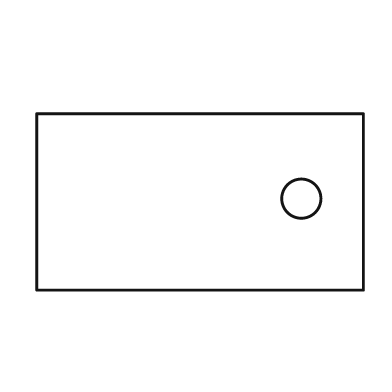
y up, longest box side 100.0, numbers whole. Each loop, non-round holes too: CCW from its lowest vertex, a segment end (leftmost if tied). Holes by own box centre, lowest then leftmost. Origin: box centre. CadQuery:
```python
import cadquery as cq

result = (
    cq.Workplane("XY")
    .moveTo(-50.0, -27.0)
    .lineTo(50.0, -27.0)
    .lineTo(50.0, 27.0)
    .lineTo(-50.0, 27.0)
    .close()
    .moveTo(31.0, 1.0)
    .circle(6.0)
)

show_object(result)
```